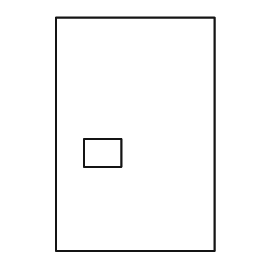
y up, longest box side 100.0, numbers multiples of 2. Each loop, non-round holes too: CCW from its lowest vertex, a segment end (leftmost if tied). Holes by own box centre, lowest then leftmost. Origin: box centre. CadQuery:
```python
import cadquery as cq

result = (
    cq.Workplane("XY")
    .moveTo(-34.0, -50.0)
    .lineTo(34.0, -50.0)
    .lineTo(34.0, 50.0)
    .lineTo(-34.0, 50.0)
    .close()
    .moveTo(-22.0, -14.0)
    .lineTo(-6.0, -14.0)
    .lineTo(-6.0, -2.0)
    .lineTo(-22.0, -2.0)
    .close()
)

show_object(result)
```